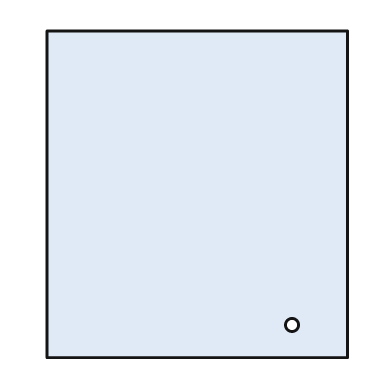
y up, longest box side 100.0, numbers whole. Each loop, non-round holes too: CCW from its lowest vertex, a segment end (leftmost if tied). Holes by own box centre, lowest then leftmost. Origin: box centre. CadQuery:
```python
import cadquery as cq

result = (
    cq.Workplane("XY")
    .moveTo(-46.0, -50.0)
    .lineTo(46.0, -50.0)
    .lineTo(46.0, 50.0)
    .lineTo(-46.0, 50.0)
    .close()
    .moveTo(29.0, -40.0)
    .circle(2.0)
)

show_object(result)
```